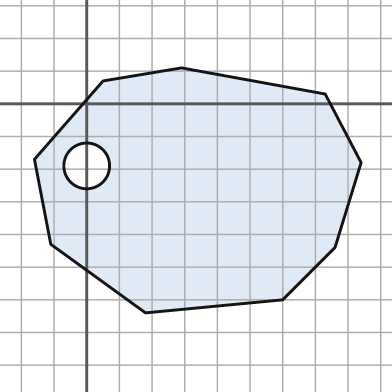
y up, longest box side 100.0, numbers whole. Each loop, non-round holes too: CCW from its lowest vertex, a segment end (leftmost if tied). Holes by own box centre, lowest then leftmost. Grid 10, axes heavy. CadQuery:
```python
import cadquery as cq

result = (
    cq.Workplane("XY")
    .moveTo(18.0, -64.0)
    .lineTo(60.0, -60.0)
    .lineTo(76.0, -44.0)
    .lineTo(84.0, -18.0)
    .lineTo(73.0, 3.0)
    .lineTo(29.0, 11.0)
    .lineTo(5.0, 7.0)
    .lineTo(-16.0, -17.0)
    .lineTo(-11.0, -43.0)
    .close()
    .moveTo(0.0, -19.0)
    .circle(7.0)
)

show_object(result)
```